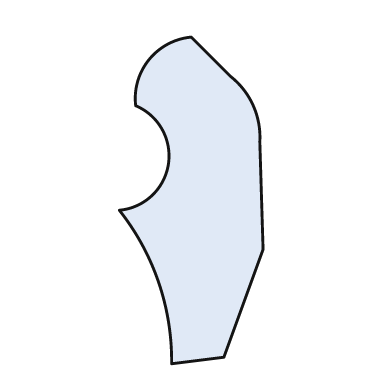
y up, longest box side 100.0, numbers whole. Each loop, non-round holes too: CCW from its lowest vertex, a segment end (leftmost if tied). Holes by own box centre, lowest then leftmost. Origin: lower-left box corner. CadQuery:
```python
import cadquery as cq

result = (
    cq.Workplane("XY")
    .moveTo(16.0, 0.0)
    .lineTo(32.0, 2.0)
    .lineTo(44.0, 35.0)
    .lineTo(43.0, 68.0)
    .threePointArc((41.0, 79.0), (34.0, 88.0))
    .lineTo(22.0, 100.0)
    .threePointArc((9.0, 93.0), (5.0, 79.0))
    .threePointArc((15.0, 61.0), (0.0, 47.0))
    .threePointArc((12.0, 25.0), (16.0, 0.0))
    .close()
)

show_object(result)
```